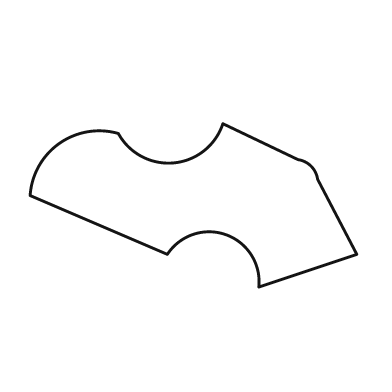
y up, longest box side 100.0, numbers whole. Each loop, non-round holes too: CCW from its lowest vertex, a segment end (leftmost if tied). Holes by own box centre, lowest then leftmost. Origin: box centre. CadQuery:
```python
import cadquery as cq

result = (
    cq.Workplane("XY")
    .moveTo(20.0, -25.0)
    .lineTo(50.0, -15.0)
    .lineTo(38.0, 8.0)
    .threePointArc((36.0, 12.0), (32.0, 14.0))
    .lineTo(9.0, 25.0)
    .threePointArc((-6.0, 13.0), (-23.0, 22.0))
    .threePointArc((-41.0, 19.0), (-50.0, 3.0))
    .lineTo(-8.0, -15.0)
    .threePointArc((10.0, -9.0), (20.0, -25.0))
    .close()
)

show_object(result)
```